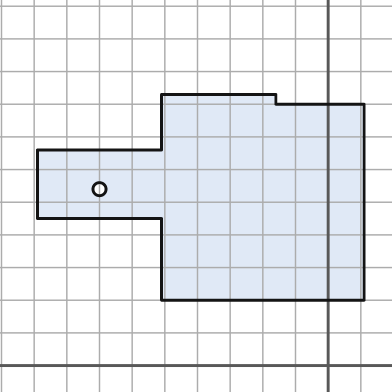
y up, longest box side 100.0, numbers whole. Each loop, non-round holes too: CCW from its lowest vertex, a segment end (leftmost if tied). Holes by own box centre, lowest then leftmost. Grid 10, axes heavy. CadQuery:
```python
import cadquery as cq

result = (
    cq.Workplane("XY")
    .moveTo(-51.0, 20.0)
    .lineTo(11.0, 20.0)
    .lineTo(11.0, 80.0)
    .lineTo(-16.0, 80.0)
    .lineTo(-16.0, 83.0)
    .lineTo(-51.0, 83.0)
    .lineTo(-51.0, 66.0)
    .lineTo(-89.0, 66.0)
    .lineTo(-89.0, 45.0)
    .lineTo(-51.0, 45.0)
    .close()
    .moveTo(-70.0, 54.0)
    .circle(2.0)
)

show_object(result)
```